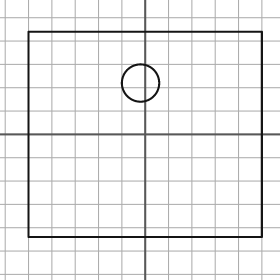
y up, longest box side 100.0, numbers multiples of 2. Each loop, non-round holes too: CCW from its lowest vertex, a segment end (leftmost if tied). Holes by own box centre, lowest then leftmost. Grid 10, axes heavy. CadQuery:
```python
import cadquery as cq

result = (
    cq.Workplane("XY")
    .moveTo(-50.0, -44.0)
    .lineTo(50.0, -44.0)
    .lineTo(50.0, 44.0)
    .lineTo(-50.0, 44.0)
    .close()
    .moveTo(-2.0, 22.0)
    .circle(8.0)
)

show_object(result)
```